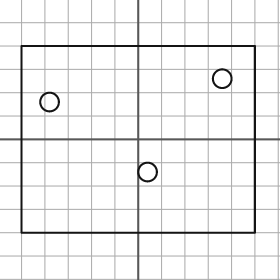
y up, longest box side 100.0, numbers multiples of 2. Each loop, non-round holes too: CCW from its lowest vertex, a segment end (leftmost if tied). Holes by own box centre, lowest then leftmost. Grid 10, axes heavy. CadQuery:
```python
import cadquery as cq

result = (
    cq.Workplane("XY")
    .moveTo(-50.0, -40.0)
    .lineTo(50.0, -40.0)
    .lineTo(50.0, 40.0)
    .lineTo(-50.0, 40.0)
    .close()
    .moveTo(4.0, -14.0)
    .circle(4.0)
    .moveTo(-38.0, 16.0)
    .circle(4.0)
    .moveTo(36.0, 26.0)
    .circle(4.0)
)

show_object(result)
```